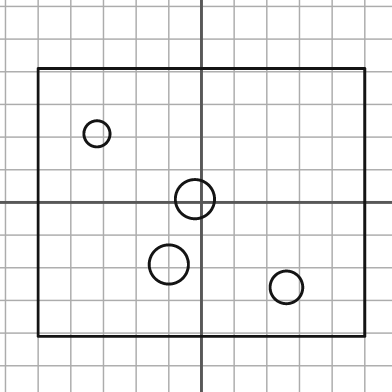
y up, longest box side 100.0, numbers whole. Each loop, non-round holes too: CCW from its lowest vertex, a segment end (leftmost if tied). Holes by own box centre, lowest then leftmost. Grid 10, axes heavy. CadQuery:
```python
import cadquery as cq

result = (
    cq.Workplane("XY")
    .moveTo(-50.0, -41.0)
    .lineTo(50.0, -41.0)
    .lineTo(50.0, 41.0)
    .lineTo(-50.0, 41.0)
    .close()
    .moveTo(26.0, -26.0)
    .circle(5.0)
    .moveTo(-10.0, -19.0)
    .circle(6.0)
    .moveTo(-2.0, 1.0)
    .circle(6.0)
    .moveTo(-32.0, 21.0)
    .circle(4.0)
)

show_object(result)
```